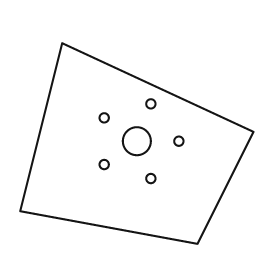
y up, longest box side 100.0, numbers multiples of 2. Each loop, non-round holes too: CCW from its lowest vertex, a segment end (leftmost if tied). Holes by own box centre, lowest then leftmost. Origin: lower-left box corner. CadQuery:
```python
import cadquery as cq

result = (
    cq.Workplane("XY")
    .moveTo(76.0, 0.0)
    .lineTo(100.0, 48.0)
    .lineTo(18.0, 86.0)
    .lineTo(0.0, 14.0)
    .close()
    .moveTo(56.0, 28.0)
    .circle(2.0)
    .moveTo(36.0, 34.0)
    .circle(2.0)
    .moveTo(50.0, 44.0)
    .circle(6.0)
    .moveTo(68.0, 44.0)
    .circle(2.0)
    .moveTo(36.0, 54.0)
    .circle(2.0)
    .moveTo(56.0, 60.0)
    .circle(2.0)
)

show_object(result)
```